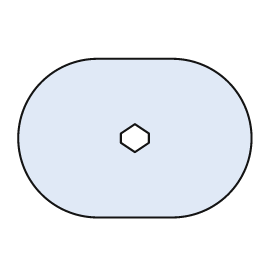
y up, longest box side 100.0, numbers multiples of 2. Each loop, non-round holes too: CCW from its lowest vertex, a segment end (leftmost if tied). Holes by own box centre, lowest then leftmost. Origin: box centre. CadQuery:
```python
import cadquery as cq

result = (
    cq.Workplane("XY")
    .moveTo(-16.0, -34.0)
    .lineTo(16.0, -34.0)
    .threePointArc((50.0, 0.0), (16.0, 34.0))
    .lineTo(-16.0, 34.0)
    .threePointArc((-50.0, 0.0), (-16.0, -34.0))
    .close()
    .moveTo(0.0, -6.0)
    .lineTo(6.0, -2.0)
    .lineTo(6.0, 2.0)
    .lineTo(0.0, 6.0)
    .lineTo(-6.0, 2.0)
    .lineTo(-6.0, -2.0)
    .close()
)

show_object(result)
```